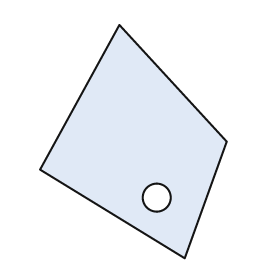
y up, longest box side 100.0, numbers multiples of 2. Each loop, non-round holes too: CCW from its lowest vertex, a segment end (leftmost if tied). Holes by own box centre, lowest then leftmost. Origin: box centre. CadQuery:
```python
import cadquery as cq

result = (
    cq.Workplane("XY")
    .moveTo(22.0, -50.0)
    .lineTo(40.0, 0.0)
    .lineTo(-6.0, 50.0)
    .lineTo(-40.0, -12.0)
    .close()
    .moveTo(10.0, -24.0)
    .circle(6.0)
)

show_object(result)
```